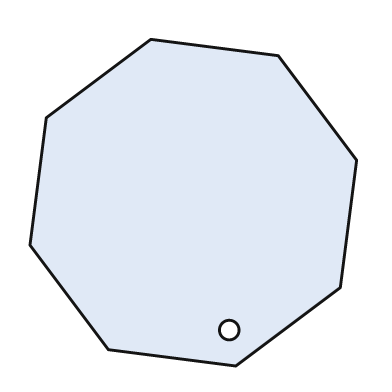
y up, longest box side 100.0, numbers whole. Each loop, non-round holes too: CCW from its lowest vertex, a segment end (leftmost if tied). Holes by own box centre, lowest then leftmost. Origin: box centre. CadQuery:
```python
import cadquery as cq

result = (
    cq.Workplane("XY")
    .moveTo(13.0, -50.0)
    .lineTo(45.0, -26.0)
    .lineTo(50.0, 13.0)
    .lineTo(26.0, 45.0)
    .lineTo(-13.0, 50.0)
    .lineTo(-45.0, 26.0)
    .lineTo(-50.0, -13.0)
    .lineTo(-26.0, -45.0)
    .close()
    .moveTo(11.0, -39.0)
    .circle(3.0)
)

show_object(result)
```